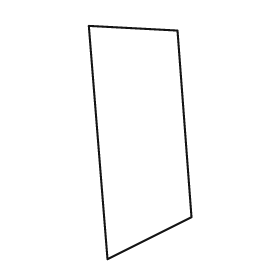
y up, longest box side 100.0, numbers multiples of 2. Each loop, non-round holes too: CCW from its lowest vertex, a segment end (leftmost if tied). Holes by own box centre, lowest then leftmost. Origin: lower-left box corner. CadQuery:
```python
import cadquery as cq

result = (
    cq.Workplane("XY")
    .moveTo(8.0, 0.0)
    .lineTo(44.0, 18.0)
    .lineTo(38.0, 98.0)
    .lineTo(0.0, 100.0)
    .close()
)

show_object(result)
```